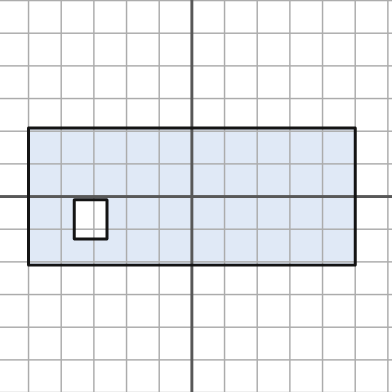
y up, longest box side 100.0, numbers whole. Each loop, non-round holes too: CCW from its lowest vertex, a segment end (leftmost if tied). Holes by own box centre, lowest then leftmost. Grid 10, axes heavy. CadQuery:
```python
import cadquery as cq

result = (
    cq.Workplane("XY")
    .moveTo(-50.0, -21.0)
    .lineTo(50.0, -21.0)
    .lineTo(50.0, 21.0)
    .lineTo(-50.0, 21.0)
    .close()
    .moveTo(-36.0, -13.0)
    .lineTo(-26.0, -13.0)
    .lineTo(-26.0, -1.0)
    .lineTo(-36.0, -1.0)
    .close()
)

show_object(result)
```